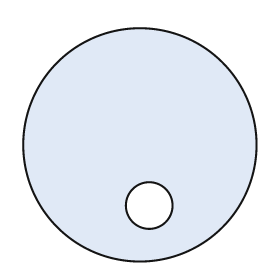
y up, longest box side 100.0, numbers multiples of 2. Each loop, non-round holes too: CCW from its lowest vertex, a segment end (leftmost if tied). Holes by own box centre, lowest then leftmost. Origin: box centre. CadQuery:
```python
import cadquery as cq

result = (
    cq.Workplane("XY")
    .moveTo(0.0, 0.0)
    .circle(50.0)
    .moveTo(4.0, -26.0)
    .circle(10.0)
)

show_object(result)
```